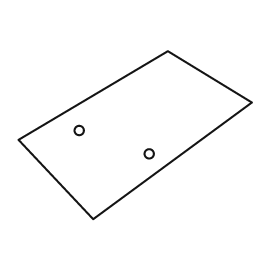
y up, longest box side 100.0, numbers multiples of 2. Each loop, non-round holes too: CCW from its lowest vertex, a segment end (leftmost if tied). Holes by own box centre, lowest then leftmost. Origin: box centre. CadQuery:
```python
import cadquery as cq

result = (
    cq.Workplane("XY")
    .moveTo(-18.0, -36.0)
    .lineTo(50.0, 14.0)
    .lineTo(14.0, 36.0)
    .lineTo(-50.0, -2.0)
    .close()
    .moveTo(6.0, -8.0)
    .circle(2.0)
    .moveTo(-24.0, 2.0)
    .circle(2.0)
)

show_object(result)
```